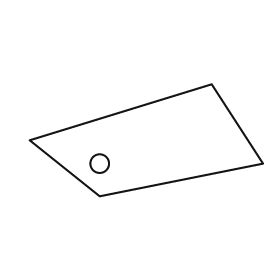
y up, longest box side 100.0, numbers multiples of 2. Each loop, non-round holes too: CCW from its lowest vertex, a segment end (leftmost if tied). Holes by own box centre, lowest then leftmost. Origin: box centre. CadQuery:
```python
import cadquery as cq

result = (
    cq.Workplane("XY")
    .moveTo(-20.0, -24.0)
    .lineTo(50.0, -10.0)
    .lineTo(28.0, 24.0)
    .lineTo(-50.0, 0.0)
    .close()
    .moveTo(-20.0, -10.0)
    .circle(4.0)
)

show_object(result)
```